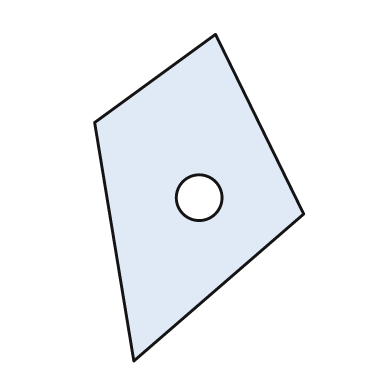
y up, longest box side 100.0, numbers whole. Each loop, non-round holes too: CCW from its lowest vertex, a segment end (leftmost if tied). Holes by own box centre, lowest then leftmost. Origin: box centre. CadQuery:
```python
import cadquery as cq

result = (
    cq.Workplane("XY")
    .moveTo(-20.0, -50.0)
    .lineTo(32.0, -5.0)
    .lineTo(5.0, 50.0)
    .lineTo(-32.0, 23.0)
    .close()
    .moveTo(0.0, 0.0)
    .circle(7.0)
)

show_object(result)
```